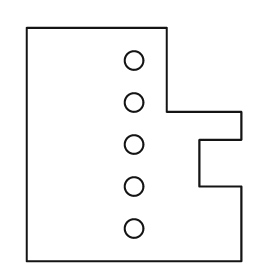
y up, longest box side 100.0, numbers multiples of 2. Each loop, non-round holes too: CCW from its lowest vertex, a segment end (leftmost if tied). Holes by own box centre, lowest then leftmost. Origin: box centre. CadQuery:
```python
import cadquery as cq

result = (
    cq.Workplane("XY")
    .moveTo(-46.0, -50.0)
    .lineTo(46.0, -50.0)
    .lineTo(46.0, -18.0)
    .lineTo(28.0, -18.0)
    .lineTo(28.0, 2.0)
    .lineTo(46.0, 2.0)
    .lineTo(46.0, 14.0)
    .lineTo(14.0, 14.0)
    .lineTo(14.0, 50.0)
    .lineTo(-46.0, 50.0)
    .close()
    .moveTo(0.0, -36.0)
    .circle(4.0)
    .moveTo(0.0, -18.0)
    .circle(4.0)
    .moveTo(0.0, 0.0)
    .circle(4.0)
    .moveTo(0.0, 18.0)
    .circle(4.0)
    .moveTo(0.0, 36.0)
    .circle(4.0)
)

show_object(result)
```